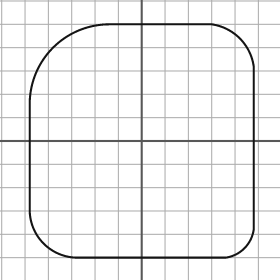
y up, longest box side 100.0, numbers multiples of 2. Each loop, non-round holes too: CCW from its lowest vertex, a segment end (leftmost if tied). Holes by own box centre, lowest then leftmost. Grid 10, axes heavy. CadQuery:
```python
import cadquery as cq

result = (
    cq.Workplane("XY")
    .moveTo(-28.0, -50.0)
    .lineTo(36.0, -50.0)
    .threePointArc((44.0, -46.0), (48.0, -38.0))
    .lineTo(48.0, 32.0)
    .threePointArc((42.0, 44.0), (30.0, 50.0))
    .lineTo(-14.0, 50.0)
    .threePointArc((-38.0, 40.0), (-48.0, 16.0))
    .lineTo(-48.0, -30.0)
    .threePointArc((-42.0, -44.0), (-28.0, -50.0))
    .close()
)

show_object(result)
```